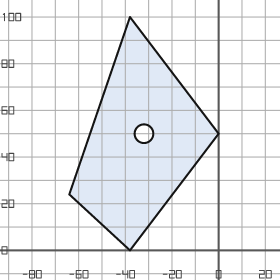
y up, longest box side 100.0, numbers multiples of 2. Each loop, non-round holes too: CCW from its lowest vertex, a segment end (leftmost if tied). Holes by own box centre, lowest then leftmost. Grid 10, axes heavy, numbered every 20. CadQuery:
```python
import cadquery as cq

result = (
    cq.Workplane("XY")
    .moveTo(-38.0, 0.0)
    .lineTo(0.0, 50.0)
    .lineTo(-38.0, 100.0)
    .lineTo(-64.0, 24.0)
    .close()
    .moveTo(-32.0, 50.0)
    .circle(4.0)
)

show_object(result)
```